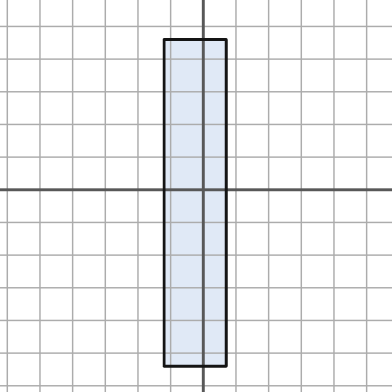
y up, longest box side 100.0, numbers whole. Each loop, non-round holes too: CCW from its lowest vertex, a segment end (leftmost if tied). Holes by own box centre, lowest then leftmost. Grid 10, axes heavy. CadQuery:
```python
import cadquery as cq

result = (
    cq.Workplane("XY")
    .moveTo(-12.0, -54.0)
    .lineTo(7.0, -54.0)
    .lineTo(7.0, 46.0)
    .lineTo(-12.0, 46.0)
    .close()
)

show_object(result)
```